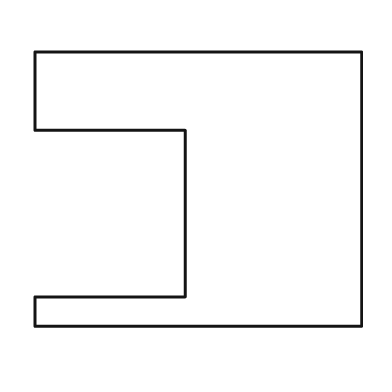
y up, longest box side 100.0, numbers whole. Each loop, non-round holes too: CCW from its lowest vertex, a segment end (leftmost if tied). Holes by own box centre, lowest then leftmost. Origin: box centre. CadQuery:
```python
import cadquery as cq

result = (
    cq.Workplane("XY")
    .moveTo(-50.0, -42.0)
    .lineTo(50.0, -42.0)
    .lineTo(50.0, 42.0)
    .lineTo(-50.0, 42.0)
    .lineTo(-50.0, 18.0)
    .lineTo(-4.0, 18.0)
    .lineTo(-4.0, -33.0)
    .lineTo(-50.0, -33.0)
    .close()
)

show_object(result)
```